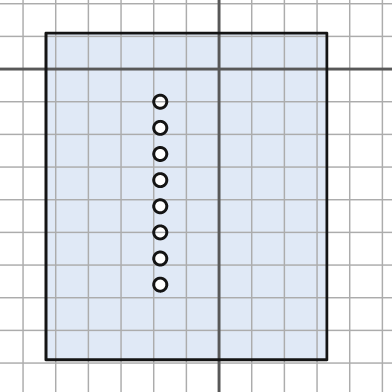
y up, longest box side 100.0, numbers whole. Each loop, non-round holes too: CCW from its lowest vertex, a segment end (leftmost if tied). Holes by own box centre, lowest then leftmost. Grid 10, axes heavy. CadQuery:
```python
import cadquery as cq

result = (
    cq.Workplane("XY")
    .moveTo(-53.0, -89.0)
    .lineTo(33.0, -89.0)
    .lineTo(33.0, 11.0)
    .lineTo(-53.0, 11.0)
    .close()
    .moveTo(-18.0, -66.0)
    .circle(2.0)
    .moveTo(-18.0, -58.0)
    .circle(2.0)
    .moveTo(-18.0, -50.0)
    .circle(2.0)
    .moveTo(-18.0, -42.0)
    .circle(2.0)
    .moveTo(-18.0, -34.0)
    .circle(2.0)
    .moveTo(-18.0, -26.0)
    .circle(2.0)
    .moveTo(-18.0, -18.0)
    .circle(2.0)
    .moveTo(-18.0, -10.0)
    .circle(2.0)
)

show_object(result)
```